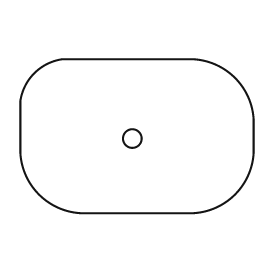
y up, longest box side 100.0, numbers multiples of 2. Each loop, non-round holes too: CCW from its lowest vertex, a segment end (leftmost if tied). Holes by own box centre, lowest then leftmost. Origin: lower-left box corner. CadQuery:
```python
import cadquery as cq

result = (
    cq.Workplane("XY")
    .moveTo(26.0, 0.0)
    .lineTo(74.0, 0.0)
    .threePointArc((92.0, 8.0), (100.0, 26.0))
    .lineTo(100.0, 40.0)
    .threePointArc((92.0, 58.0), (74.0, 66.0))
    .lineTo(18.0, 66.0)
    .threePointArc((6.0, 60.0), (0.0, 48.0))
    .lineTo(0.0, 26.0)
    .threePointArc((8.0, 8.0), (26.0, 0.0))
    .close()
    .moveTo(48.0, 32.0)
    .circle(4.0)
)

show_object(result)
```